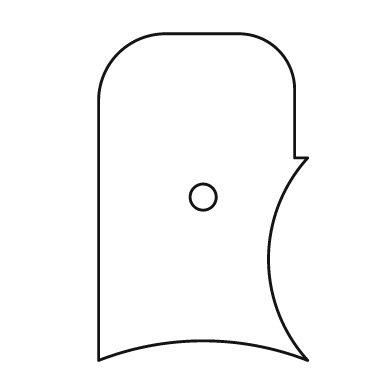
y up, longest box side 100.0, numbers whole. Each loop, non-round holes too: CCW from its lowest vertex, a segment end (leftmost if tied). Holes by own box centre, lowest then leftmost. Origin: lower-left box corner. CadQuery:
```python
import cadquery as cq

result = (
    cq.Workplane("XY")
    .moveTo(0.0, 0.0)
    .threePointArc((32.0, 6.0), (64.0, 0.0))
    .threePointArc((52.0, 31.0), (64.0, 62.0))
    .lineTo(60.0, 62.0)
    .lineTo(60.0, 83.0)
    .threePointArc((55.0, 95.0), (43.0, 100.0))
    .lineTo(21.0, 100.0)
    .threePointArc((6.0, 94.0), (0.0, 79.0))
    .close()
    .moveTo(32.0, 50.0)
    .circle(4.0)
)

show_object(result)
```